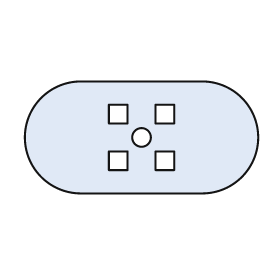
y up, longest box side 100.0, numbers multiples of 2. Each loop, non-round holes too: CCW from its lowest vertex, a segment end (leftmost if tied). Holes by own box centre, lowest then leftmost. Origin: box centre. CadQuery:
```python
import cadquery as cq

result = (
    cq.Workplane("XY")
    .moveTo(-26.0, -24.0)
    .lineTo(26.0, -24.0)
    .threePointArc((50.0, 0.0), (26.0, 24.0))
    .lineTo(-26.0, 24.0)
    .threePointArc((-50.0, 0.0), (-26.0, -24.0))
    .close()
    .moveTo(-14.0, -14.0)
    .lineTo(-6.0, -14.0)
    .lineTo(-6.0, -6.0)
    .lineTo(-14.0, -6.0)
    .close()
    .moveTo(6.0, -14.0)
    .lineTo(14.0, -14.0)
    .lineTo(14.0, -6.0)
    .lineTo(6.0, -6.0)
    .close()
    .moveTo(0.0, 0.0)
    .circle(4.0)
    .moveTo(-14.0, 6.0)
    .lineTo(-6.0, 6.0)
    .lineTo(-6.0, 14.0)
    .lineTo(-14.0, 14.0)
    .close()
    .moveTo(6.0, 6.0)
    .lineTo(14.0, 6.0)
    .lineTo(14.0, 14.0)
    .lineTo(6.0, 14.0)
    .close()
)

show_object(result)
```